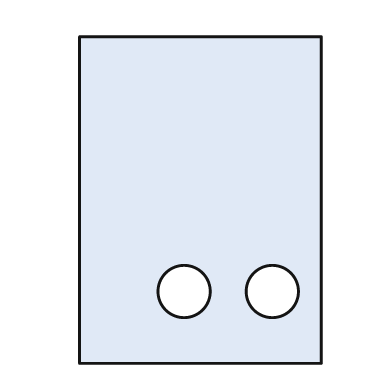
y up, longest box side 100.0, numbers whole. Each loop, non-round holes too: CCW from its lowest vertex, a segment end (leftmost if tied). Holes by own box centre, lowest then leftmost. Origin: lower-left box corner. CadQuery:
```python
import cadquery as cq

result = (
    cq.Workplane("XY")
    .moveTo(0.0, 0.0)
    .lineTo(74.0, 0.0)
    .lineTo(74.0, 100.0)
    .lineTo(0.0, 100.0)
    .close()
    .moveTo(32.0, 22.0)
    .circle(8.0)
    .moveTo(59.0, 22.0)
    .circle(8.0)
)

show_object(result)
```